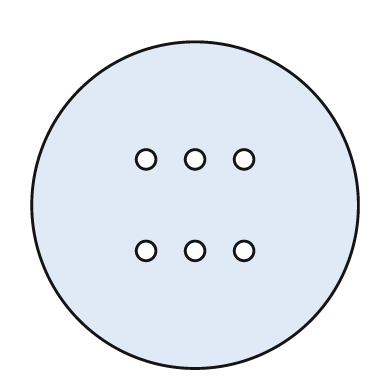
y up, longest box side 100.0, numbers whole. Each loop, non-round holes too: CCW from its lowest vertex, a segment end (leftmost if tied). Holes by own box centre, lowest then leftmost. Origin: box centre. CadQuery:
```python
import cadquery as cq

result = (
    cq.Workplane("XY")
    .moveTo(0.0, 0.0)
    .circle(50.0)
    .moveTo(-15.0, -14.0)
    .circle(3.0)
    .moveTo(0.0, -14.0)
    .circle(3.0)
    .moveTo(15.0, -14.0)
    .circle(3.0)
    .moveTo(-15.0, 14.0)
    .circle(3.0)
    .moveTo(0.0, 14.0)
    .circle(3.0)
    .moveTo(15.0, 14.0)
    .circle(3.0)
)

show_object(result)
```